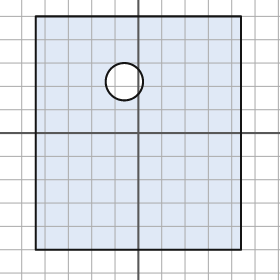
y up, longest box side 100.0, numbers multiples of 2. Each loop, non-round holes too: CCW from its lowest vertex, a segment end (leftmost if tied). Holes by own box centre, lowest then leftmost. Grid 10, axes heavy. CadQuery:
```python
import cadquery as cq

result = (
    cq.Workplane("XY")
    .moveTo(-44.0, -50.0)
    .lineTo(44.0, -50.0)
    .lineTo(44.0, 50.0)
    .lineTo(-44.0, 50.0)
    .close()
    .moveTo(-6.0, 22.0)
    .circle(8.0)
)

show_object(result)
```